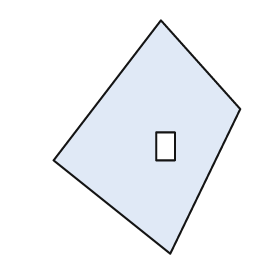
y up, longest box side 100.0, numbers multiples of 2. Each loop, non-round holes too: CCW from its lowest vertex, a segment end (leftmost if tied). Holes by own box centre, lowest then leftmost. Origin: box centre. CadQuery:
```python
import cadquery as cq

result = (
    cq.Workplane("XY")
    .moveTo(10.0, -50.0)
    .lineTo(40.0, 12.0)
    .lineTo(6.0, 50.0)
    .lineTo(-40.0, -10.0)
    .close()
    .moveTo(4.0, -10.0)
    .lineTo(12.0, -10.0)
    .lineTo(12.0, 2.0)
    .lineTo(4.0, 2.0)
    .close()
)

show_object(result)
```